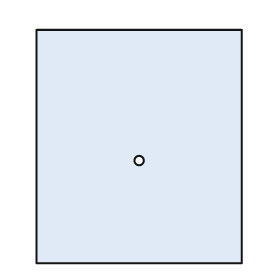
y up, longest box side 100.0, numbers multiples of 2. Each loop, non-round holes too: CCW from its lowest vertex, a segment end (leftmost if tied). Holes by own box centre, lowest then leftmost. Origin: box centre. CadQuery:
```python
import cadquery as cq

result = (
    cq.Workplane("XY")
    .moveTo(-44.0, -50.0)
    .lineTo(44.0, -50.0)
    .lineTo(44.0, 50.0)
    .lineTo(-44.0, 50.0)
    .close()
    .moveTo(0.0, -6.0)
    .circle(2.0)
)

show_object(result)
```